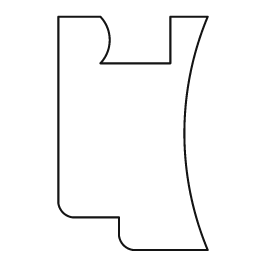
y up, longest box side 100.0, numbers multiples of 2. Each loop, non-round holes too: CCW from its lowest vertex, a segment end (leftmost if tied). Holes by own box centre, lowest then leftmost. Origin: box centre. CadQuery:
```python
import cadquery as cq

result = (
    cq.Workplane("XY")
    .moveTo(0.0, -50.0)
    .lineTo(32.0, -50.0)
    .threePointArc((22.0, 0.0), (32.0, 50.0))
    .lineTo(16.0, 50.0)
    .lineTo(16.0, 30.0)
    .lineTo(-14.0, 30.0)
    .threePointArc((-10.0, 40.0), (-14.0, 50.0))
    .lineTo(-32.0, 50.0)
    .lineTo(-32.0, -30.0)
    .threePointArc((-30.0, -34.0), (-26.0, -36.0))
    .lineTo(-6.0, -36.0)
    .lineTo(-6.0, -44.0)
    .threePointArc((-4.0, -48.0), (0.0, -50.0))
    .close()
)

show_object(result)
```